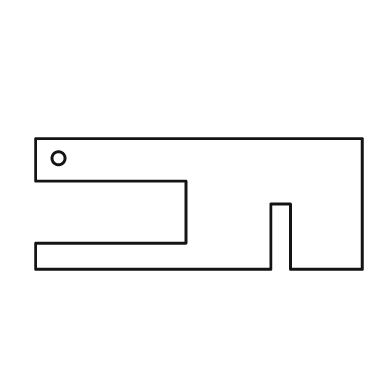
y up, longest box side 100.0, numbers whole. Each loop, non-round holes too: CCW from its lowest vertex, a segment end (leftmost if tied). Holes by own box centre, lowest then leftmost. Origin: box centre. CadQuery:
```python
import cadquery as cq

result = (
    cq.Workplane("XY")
    .moveTo(-50.0, -20.0)
    .lineTo(22.0, -20.0)
    .lineTo(22.0, 0.0)
    .lineTo(28.0, 0.0)
    .lineTo(28.0, -20.0)
    .lineTo(50.0, -20.0)
    .lineTo(50.0, 20.0)
    .lineTo(-50.0, 20.0)
    .lineTo(-50.0, 7.0)
    .lineTo(-4.0, 7.0)
    .lineTo(-4.0, -12.0)
    .lineTo(-50.0, -12.0)
    .close()
    .moveTo(-43.0, 14.0)
    .circle(2.0)
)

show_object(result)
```